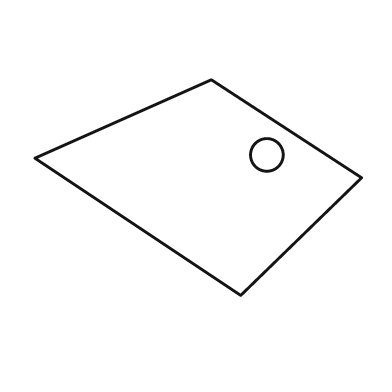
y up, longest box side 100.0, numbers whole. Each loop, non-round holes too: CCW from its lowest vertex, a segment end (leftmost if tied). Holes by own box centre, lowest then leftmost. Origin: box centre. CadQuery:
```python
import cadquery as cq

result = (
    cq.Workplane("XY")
    .moveTo(13.0, -33.0)
    .lineTo(50.0, 3.0)
    .lineTo(4.0, 33.0)
    .lineTo(-50.0, 9.0)
    .close()
    .moveTo(21.0, 10.0)
    .circle(5.0)
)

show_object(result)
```